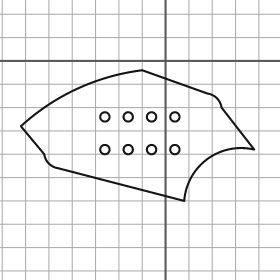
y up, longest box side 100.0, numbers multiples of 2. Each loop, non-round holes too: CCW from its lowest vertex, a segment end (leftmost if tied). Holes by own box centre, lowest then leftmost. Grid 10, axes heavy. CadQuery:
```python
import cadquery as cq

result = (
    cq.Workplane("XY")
    .moveTo(8.0, -60.0)
    .threePointArc((18.0, -42.0), (38.0, -38.0))
    .lineTo(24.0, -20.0)
    .threePointArc((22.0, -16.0), (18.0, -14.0))
    .lineTo(-10.0, -4.0)
    .threePointArc((-38.0, -12.0), (-62.0, -28.0))
    .lineTo(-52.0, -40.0)
    .threePointArc((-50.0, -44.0), (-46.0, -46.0))
    .close()
    .moveTo(-26.0, -38.0)
    .circle(2.0)
    .moveTo(-16.0, -38.0)
    .circle(2.0)
    .moveTo(-6.0, -38.0)
    .circle(2.0)
    .moveTo(4.0, -38.0)
    .circle(2.0)
    .moveTo(-26.0, -24.0)
    .circle(2.0)
    .moveTo(-16.0, -24.0)
    .circle(2.0)
    .moveTo(-6.0, -24.0)
    .circle(2.0)
    .moveTo(4.0, -24.0)
    .circle(2.0)
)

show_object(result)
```